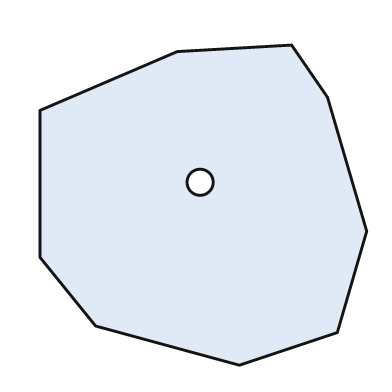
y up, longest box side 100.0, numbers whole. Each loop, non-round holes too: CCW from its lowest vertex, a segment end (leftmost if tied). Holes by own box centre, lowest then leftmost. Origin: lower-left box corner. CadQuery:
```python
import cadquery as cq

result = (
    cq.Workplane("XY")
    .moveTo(61.0, 0.0)
    .lineTo(91.0, 10.0)
    .lineTo(100.0, 41.0)
    .lineTo(88.0, 82.0)
    .lineTo(77.0, 98.0)
    .lineTo(42.0, 96.0)
    .lineTo(0.0, 78.0)
    .lineTo(0.0, 33.0)
    .lineTo(17.0, 12.0)
    .close()
    .moveTo(49.0, 56.0)
    .circle(4.0)
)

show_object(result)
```